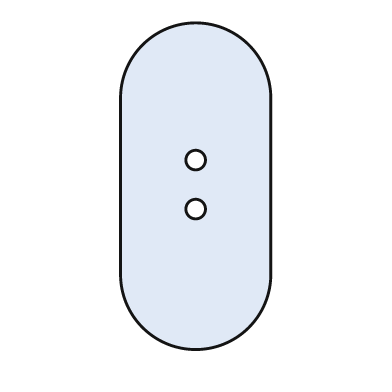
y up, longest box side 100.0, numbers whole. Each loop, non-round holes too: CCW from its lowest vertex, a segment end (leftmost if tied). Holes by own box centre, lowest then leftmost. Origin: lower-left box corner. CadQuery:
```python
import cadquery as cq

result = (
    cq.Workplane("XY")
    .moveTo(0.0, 23.0)
    .threePointArc((23.0, 0.0), (46.0, 23.0))
    .lineTo(46.0, 77.0)
    .threePointArc((23.0, 100.0), (0.0, 77.0))
    .close()
    .moveTo(23.0, 43.0)
    .circle(3.0)
    .moveTo(23.0, 58.0)
    .circle(3.0)
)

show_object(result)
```